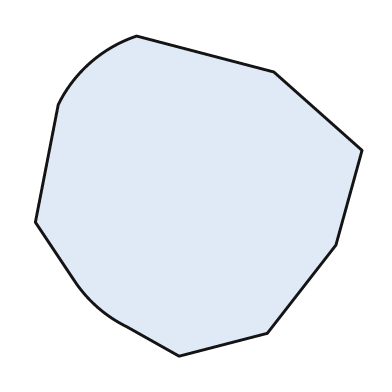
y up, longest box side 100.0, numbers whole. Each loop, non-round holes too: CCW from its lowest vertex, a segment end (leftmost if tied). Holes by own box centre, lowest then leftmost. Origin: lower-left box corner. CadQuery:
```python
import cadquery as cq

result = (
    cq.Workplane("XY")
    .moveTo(44.0, 0.0)
    .lineTo(71.0, 7.0)
    .lineTo(92.0, 34.0)
    .lineTo(100.0, 63.0)
    .lineTo(73.0, 87.0)
    .lineTo(31.0, 98.0)
    .threePointArc((17.0, 90.0), (7.0, 77.0))
    .lineTo(0.0, 41.0)
    .lineTo(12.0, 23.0)
    .threePointArc((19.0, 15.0), (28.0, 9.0))
    .close()
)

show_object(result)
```